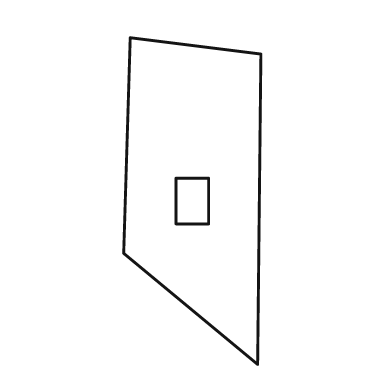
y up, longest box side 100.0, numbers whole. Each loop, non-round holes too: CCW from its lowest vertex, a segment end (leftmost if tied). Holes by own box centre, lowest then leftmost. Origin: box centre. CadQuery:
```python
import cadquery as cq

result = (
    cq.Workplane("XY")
    .moveTo(20.0, -50.0)
    .lineTo(21.0, 45.0)
    .lineTo(-19.0, 50.0)
    .lineTo(-21.0, -16.0)
    .close()
    .moveTo(-5.0, -7.0)
    .lineTo(5.0, -7.0)
    .lineTo(5.0, 7.0)
    .lineTo(-5.0, 7.0)
    .close()
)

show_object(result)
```